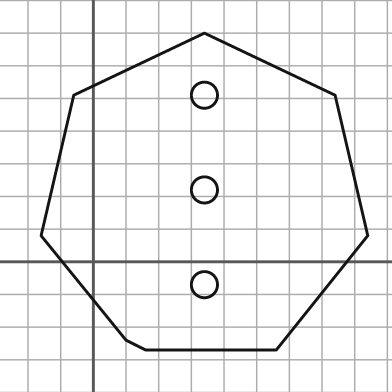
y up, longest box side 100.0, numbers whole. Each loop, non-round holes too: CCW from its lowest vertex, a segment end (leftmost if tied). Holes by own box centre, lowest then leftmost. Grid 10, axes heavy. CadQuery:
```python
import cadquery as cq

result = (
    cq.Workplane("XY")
    .moveTo(16.0, -27.0)
    .lineTo(56.0, -27.0)
    .lineTo(84.0, 8.0)
    .lineTo(74.0, 51.0)
    .lineTo(34.0, 70.0)
    .lineTo(-6.0, 51.0)
    .lineTo(-16.0, 8.0)
    .lineTo(10.0, -24.0)
    .close()
    .moveTo(34.0, -7.0)
    .circle(4.0)
    .moveTo(34.0, 22.0)
    .circle(4.0)
    .moveTo(34.0, 51.0)
    .circle(4.0)
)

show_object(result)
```